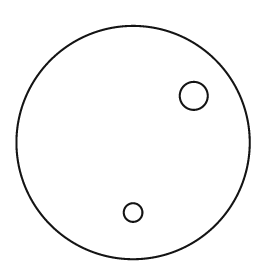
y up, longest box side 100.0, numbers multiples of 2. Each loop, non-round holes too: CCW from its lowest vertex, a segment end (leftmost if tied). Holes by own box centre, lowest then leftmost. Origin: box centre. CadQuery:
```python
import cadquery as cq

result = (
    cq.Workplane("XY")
    .moveTo(0.0, 0.0)
    .circle(50.0)
    .moveTo(0.0, -30.0)
    .circle(4.0)
    .moveTo(26.0, 20.0)
    .circle(6.0)
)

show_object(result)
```